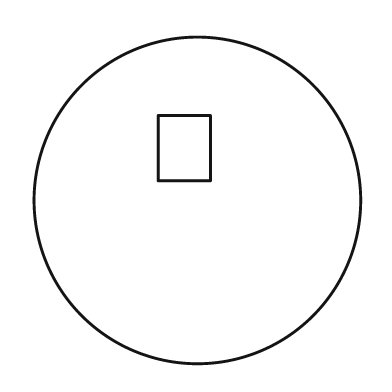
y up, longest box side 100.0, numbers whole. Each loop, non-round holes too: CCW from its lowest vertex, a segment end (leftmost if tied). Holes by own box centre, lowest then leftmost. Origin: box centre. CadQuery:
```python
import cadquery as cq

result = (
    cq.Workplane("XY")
    .moveTo(0.0, 0.0)
    .circle(50.0)
    .moveTo(-12.0, 6.0)
    .lineTo(4.0, 6.0)
    .lineTo(4.0, 26.0)
    .lineTo(-12.0, 26.0)
    .close()
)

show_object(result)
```